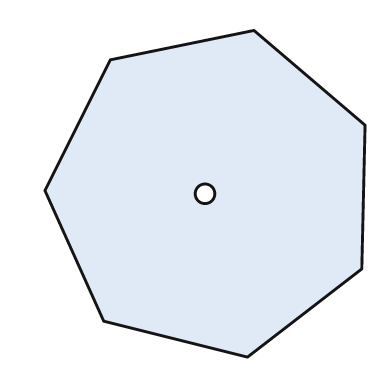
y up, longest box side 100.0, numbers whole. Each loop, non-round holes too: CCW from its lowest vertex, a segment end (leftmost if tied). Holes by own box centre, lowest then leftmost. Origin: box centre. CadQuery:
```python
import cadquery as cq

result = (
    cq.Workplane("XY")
    .moveTo(13.0, -50.0)
    .lineTo(48.0, -23.0)
    .lineTo(49.0, 21.0)
    .lineTo(15.0, 50.0)
    .lineTo(-29.0, 41.0)
    .lineTo(-49.0, 1.0)
    .lineTo(-31.0, -39.0)
    .close()
    .moveTo(0.0, 0.0)
    .circle(3.0)
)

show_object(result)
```